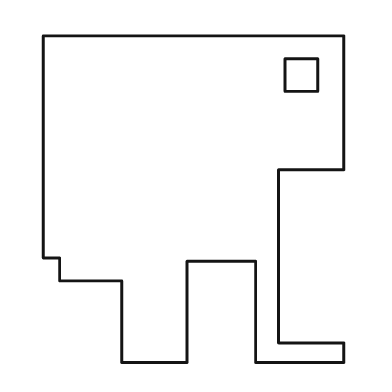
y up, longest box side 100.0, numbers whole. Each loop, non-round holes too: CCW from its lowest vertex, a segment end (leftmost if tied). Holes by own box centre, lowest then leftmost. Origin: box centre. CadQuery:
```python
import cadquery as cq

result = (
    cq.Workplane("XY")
    .moveTo(-22.0, -50.0)
    .lineTo(-2.0, -50.0)
    .lineTo(-2.0, -19.0)
    .lineTo(19.0, -19.0)
    .lineTo(19.0, -50.0)
    .lineTo(46.0, -50.0)
    .lineTo(46.0, -44.0)
    .lineTo(26.0, -44.0)
    .lineTo(26.0, 9.0)
    .lineTo(46.0, 9.0)
    .lineTo(46.0, 50.0)
    .lineTo(-46.0, 50.0)
    .lineTo(-46.0, -18.0)
    .lineTo(-41.0, -18.0)
    .lineTo(-41.0, -25.0)
    .lineTo(-22.0, -25.0)
    .close()
    .moveTo(28.0, 33.0)
    .lineTo(38.0, 33.0)
    .lineTo(38.0, 43.0)
    .lineTo(28.0, 43.0)
    .close()
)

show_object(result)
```